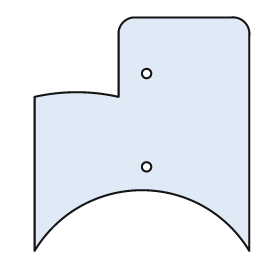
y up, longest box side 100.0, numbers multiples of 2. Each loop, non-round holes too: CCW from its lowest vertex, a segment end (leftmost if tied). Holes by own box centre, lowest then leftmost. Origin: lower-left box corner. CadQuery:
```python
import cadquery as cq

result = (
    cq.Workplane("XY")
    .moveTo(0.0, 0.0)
    .threePointArc((46.0, 26.0), (92.0, 0.0))
    .lineTo(92.0, 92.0)
    .threePointArc((90.0, 98.0), (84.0, 100.0))
    .lineTo(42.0, 100.0)
    .threePointArc((38.0, 98.0), (36.0, 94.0))
    .lineTo(36.0, 66.0)
    .threePointArc((18.0, 68.0), (0.0, 66.0))
    .close()
    .moveTo(48.0, 36.0)
    .circle(2.0)
    .moveTo(48.0, 76.0)
    .circle(2.0)
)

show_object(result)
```